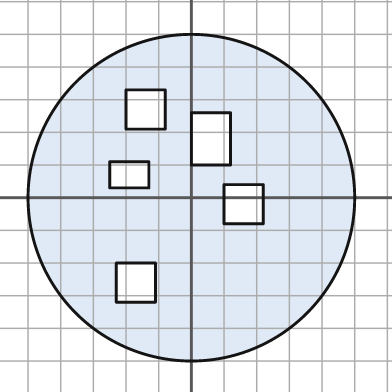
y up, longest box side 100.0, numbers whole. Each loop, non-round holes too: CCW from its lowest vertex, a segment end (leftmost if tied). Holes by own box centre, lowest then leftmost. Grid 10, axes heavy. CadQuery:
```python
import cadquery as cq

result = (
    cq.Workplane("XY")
    .moveTo(0.0, 0.0)
    .circle(50.0)
    .moveTo(-23.0, -32.0)
    .lineTo(-11.0, -32.0)
    .lineTo(-11.0, -20.0)
    .lineTo(-23.0, -20.0)
    .close()
    .moveTo(10.0, -8.0)
    .lineTo(22.0, -8.0)
    .lineTo(22.0, 4.0)
    .lineTo(10.0, 4.0)
    .close()
    .moveTo(-25.0, 3.0)
    .lineTo(-13.0, 3.0)
    .lineTo(-13.0, 11.0)
    .lineTo(-25.0, 11.0)
    .close()
    .moveTo(0.0, 10.0)
    .lineTo(12.0, 10.0)
    .lineTo(12.0, 26.0)
    .lineTo(0.0, 26.0)
    .close()
    .moveTo(-20.0, 21.0)
    .lineTo(-8.0, 21.0)
    .lineTo(-8.0, 33.0)
    .lineTo(-20.0, 33.0)
    .close()
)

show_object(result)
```